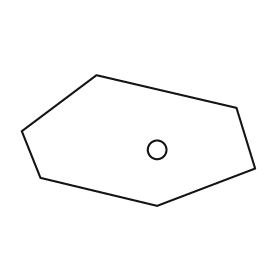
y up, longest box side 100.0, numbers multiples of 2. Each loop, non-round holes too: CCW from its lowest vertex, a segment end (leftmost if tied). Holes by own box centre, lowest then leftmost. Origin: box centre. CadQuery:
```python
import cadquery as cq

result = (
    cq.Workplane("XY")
    .moveTo(8.0, -28.0)
    .lineTo(50.0, -12.0)
    .lineTo(42.0, 14.0)
    .lineTo(-18.0, 28.0)
    .lineTo(-50.0, 4.0)
    .lineTo(-42.0, -16.0)
    .close()
    .moveTo(8.0, -4.0)
    .circle(4.0)
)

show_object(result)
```